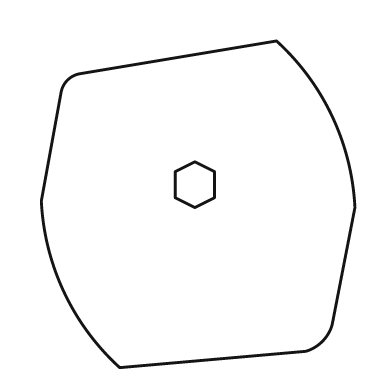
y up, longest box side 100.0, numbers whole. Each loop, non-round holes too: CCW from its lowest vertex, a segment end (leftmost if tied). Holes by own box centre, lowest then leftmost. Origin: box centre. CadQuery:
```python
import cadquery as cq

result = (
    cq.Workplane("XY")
    .moveTo(-24.0, -50.0)
    .lineTo(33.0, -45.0)
    .threePointArc((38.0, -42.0), (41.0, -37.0))
    .lineTo(48.0, -1.0)
    .threePointArc((41.0, 27.0), (24.0, 50.0))
    .lineTo(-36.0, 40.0)
    .threePointArc((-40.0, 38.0), (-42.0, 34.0))
    .lineTo(-48.0, 1.0)
    .threePointArc((-41.0, -27.0), (-24.0, -50.0))
    .close()
    .moveTo(-1.0, -1.0)
    .lineTo(5.0, 2.0)
    .lineTo(5.0, 10.0)
    .lineTo(-1.0, 13.0)
    .lineTo(-7.0, 10.0)
    .lineTo(-7.0, 2.0)
    .close()
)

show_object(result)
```